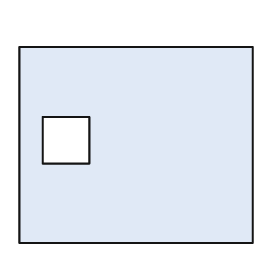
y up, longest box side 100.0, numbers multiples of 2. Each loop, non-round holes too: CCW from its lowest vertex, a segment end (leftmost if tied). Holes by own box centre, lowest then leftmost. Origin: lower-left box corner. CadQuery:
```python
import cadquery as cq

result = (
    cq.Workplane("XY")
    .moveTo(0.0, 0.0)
    .lineTo(100.0, 0.0)
    .lineTo(100.0, 84.0)
    .lineTo(0.0, 84.0)
    .close()
    .moveTo(10.0, 34.0)
    .lineTo(30.0, 34.0)
    .lineTo(30.0, 54.0)
    .lineTo(10.0, 54.0)
    .close()
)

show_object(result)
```